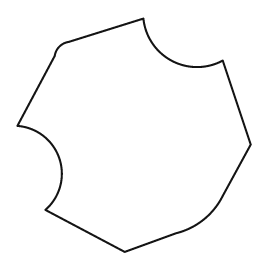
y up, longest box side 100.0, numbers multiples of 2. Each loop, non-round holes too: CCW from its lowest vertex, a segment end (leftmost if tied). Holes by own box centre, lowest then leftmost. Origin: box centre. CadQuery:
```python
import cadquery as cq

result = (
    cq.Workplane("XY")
    .moveTo(-4.0, -50.0)
    .lineTo(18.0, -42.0)
    .threePointArc((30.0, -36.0), (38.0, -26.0))
    .lineTo(50.0, -4.0)
    .lineTo(38.0, 32.0)
    .threePointArc((16.0, 32.0), (4.0, 50.0))
    .lineTo(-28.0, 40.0)
    .threePointArc((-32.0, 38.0), (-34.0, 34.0))
    .lineTo(-50.0, 4.0)
    .threePointArc((-32.0, -10.0), (-38.0, -32.0))
    .close()
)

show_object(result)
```